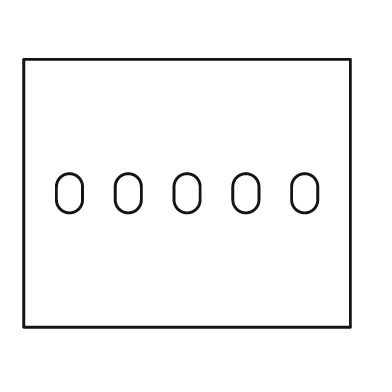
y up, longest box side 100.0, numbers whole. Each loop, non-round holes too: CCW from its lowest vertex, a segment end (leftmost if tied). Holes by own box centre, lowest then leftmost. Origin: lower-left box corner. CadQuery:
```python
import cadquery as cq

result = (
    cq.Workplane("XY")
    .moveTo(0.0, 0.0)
    .lineTo(100.0, 0.0)
    .lineTo(100.0, 82.0)
    .lineTo(0.0, 82.0)
    .close()
    .moveTo(10.0, 39.0)
    .threePointArc((14.0, 35.0), (18.0, 39.0))
    .lineTo(18.0, 43.0)
    .threePointArc((14.0, 47.0), (10.0, 43.0))
    .close()
    .moveTo(28.0, 39.0)
    .threePointArc((32.0, 35.0), (36.0, 39.0))
    .lineTo(36.0, 43.0)
    .threePointArc((32.0, 47.0), (28.0, 43.0))
    .close()
    .moveTo(46.0, 39.0)
    .threePointArc((50.0, 35.0), (54.0, 39.0))
    .lineTo(54.0, 43.0)
    .threePointArc((50.0, 47.0), (46.0, 43.0))
    .close()
    .moveTo(64.0, 39.0)
    .threePointArc((68.0, 35.0), (72.0, 39.0))
    .lineTo(72.0, 43.0)
    .threePointArc((68.0, 47.0), (64.0, 43.0))
    .close()
    .moveTo(82.0, 39.0)
    .threePointArc((86.0, 35.0), (90.0, 39.0))
    .lineTo(90.0, 43.0)
    .threePointArc((86.0, 47.0), (82.0, 43.0))
    .close()
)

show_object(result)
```